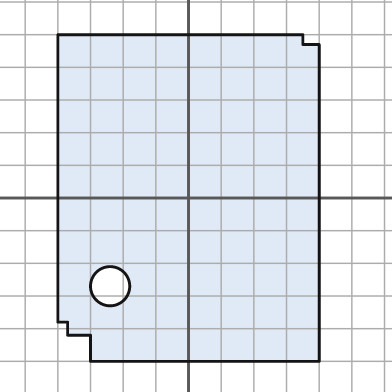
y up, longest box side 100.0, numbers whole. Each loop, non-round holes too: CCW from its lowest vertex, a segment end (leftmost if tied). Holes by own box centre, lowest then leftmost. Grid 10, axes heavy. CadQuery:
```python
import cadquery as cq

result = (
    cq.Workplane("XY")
    .moveTo(-30.0, -50.0)
    .lineTo(40.0, -50.0)
    .lineTo(40.0, 47.0)
    .lineTo(35.0, 47.0)
    .lineTo(35.0, 50.0)
    .lineTo(-40.0, 50.0)
    .lineTo(-40.0, -38.0)
    .lineTo(-37.0, -38.0)
    .lineTo(-37.0, -42.0)
    .lineTo(-30.0, -42.0)
    .close()
    .moveTo(-24.0, -27.0)
    .circle(6.0)
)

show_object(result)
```